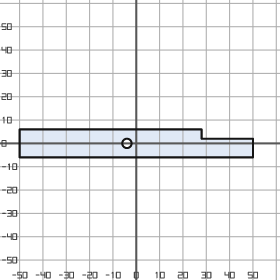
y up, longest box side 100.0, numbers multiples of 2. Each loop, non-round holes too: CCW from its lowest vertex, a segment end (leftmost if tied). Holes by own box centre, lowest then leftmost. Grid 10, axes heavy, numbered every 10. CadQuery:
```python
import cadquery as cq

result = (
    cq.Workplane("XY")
    .moveTo(-50.0, -6.0)
    .lineTo(50.0, -6.0)
    .lineTo(50.0, 2.0)
    .lineTo(28.0, 2.0)
    .lineTo(28.0, 6.0)
    .lineTo(-50.0, 6.0)
    .close()
    .moveTo(-4.0, 0.0)
    .circle(2.0)
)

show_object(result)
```